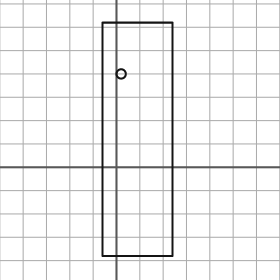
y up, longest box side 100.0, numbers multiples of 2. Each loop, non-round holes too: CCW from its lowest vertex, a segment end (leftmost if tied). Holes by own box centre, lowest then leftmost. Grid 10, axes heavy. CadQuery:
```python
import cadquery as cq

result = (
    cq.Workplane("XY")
    .moveTo(-6.0, -38.0)
    .lineTo(24.0, -38.0)
    .lineTo(24.0, 62.0)
    .lineTo(-6.0, 62.0)
    .close()
    .moveTo(2.0, 40.0)
    .circle(2.0)
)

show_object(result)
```